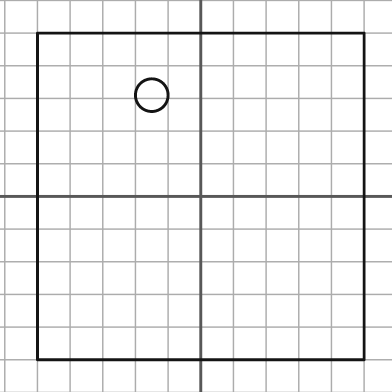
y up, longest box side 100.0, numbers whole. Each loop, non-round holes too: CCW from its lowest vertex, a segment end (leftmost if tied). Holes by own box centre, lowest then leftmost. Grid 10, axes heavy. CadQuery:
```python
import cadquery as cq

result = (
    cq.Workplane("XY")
    .moveTo(-50.0, -50.0)
    .lineTo(50.0, -50.0)
    .lineTo(50.0, 50.0)
    .lineTo(-50.0, 50.0)
    .close()
    .moveTo(-15.0, 31.0)
    .circle(5.0)
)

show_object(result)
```